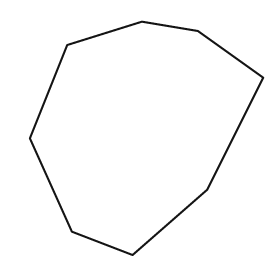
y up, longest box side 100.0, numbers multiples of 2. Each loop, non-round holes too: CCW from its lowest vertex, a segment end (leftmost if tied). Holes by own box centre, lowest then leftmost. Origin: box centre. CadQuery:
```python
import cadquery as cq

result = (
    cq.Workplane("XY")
    .moveTo(-6.0, -50.0)
    .lineTo(26.0, -22.0)
    .lineTo(50.0, 26.0)
    .lineTo(22.0, 46.0)
    .lineTo(-2.0, 50.0)
    .lineTo(-34.0, 40.0)
    .lineTo(-50.0, 0.0)
    .lineTo(-32.0, -40.0)
    .close()
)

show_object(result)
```